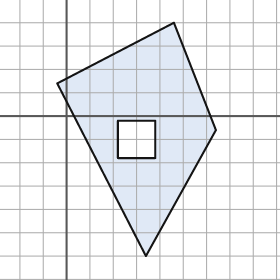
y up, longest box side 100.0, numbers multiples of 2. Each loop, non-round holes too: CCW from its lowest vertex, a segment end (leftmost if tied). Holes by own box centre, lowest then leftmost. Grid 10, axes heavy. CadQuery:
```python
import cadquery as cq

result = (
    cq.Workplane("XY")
    .moveTo(34.0, -60.0)
    .lineTo(64.0, -6.0)
    .lineTo(46.0, 40.0)
    .lineTo(-4.0, 14.0)
    .close()
    .moveTo(22.0, -18.0)
    .lineTo(38.0, -18.0)
    .lineTo(38.0, -2.0)
    .lineTo(22.0, -2.0)
    .close()
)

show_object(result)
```